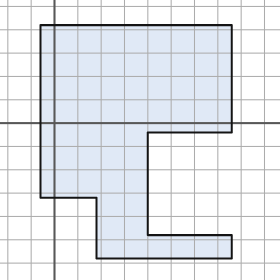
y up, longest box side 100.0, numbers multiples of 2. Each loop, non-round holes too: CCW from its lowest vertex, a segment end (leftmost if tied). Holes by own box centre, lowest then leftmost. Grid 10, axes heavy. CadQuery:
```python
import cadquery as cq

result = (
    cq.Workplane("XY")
    .moveTo(18.0, -58.0)
    .lineTo(76.0, -58.0)
    .lineTo(76.0, -48.0)
    .lineTo(40.0, -48.0)
    .lineTo(40.0, -4.0)
    .lineTo(76.0, -4.0)
    .lineTo(76.0, 42.0)
    .lineTo(-6.0, 42.0)
    .lineTo(-6.0, -32.0)
    .lineTo(18.0, -32.0)
    .close()
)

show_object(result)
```